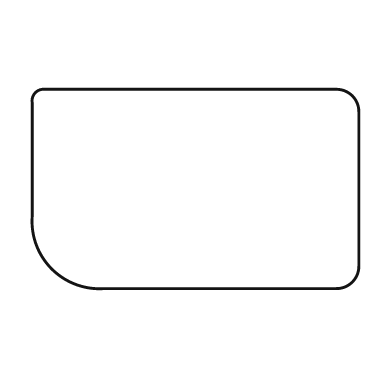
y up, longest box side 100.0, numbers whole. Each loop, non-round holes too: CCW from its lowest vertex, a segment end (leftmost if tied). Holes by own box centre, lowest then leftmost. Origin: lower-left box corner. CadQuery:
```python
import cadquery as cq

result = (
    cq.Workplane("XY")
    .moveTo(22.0, 0.0)
    .lineTo(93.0, 0.0)
    .threePointArc((98.0, 2.0), (100.0, 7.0))
    .lineTo(100.0, 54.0)
    .threePointArc((98.0, 59.0), (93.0, 61.0))
    .lineTo(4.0, 61.0)
    .threePointArc((1.0, 60.0), (0.0, 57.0))
    .lineTo(0.0, 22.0)
    .threePointArc((6.0, 6.0), (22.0, 0.0))
    .close()
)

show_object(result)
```